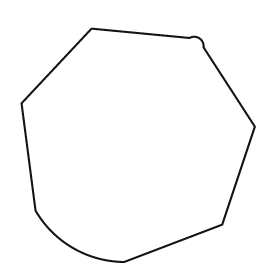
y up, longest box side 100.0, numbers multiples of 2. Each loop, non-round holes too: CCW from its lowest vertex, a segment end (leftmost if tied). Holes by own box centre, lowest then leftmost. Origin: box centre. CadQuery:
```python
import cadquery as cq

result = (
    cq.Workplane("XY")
    .moveTo(-6.0, -50.0)
    .lineTo(36.0, -34.0)
    .lineTo(50.0, 8.0)
    .lineTo(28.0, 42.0)
    .threePointArc((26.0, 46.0), (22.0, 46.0))
    .lineTo(-20.0, 50.0)
    .lineTo(-50.0, 18.0)
    .lineTo(-44.0, -28.0)
    .threePointArc((-28.0, -44.0), (-6.0, -50.0))
    .close()
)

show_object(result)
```